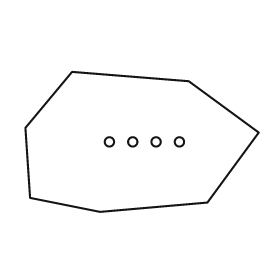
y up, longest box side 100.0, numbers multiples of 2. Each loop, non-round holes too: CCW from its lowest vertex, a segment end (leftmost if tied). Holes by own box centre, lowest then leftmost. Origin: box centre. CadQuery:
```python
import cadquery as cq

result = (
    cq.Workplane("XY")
    .moveTo(-18.0, -30.0)
    .lineTo(28.0, -26.0)
    .lineTo(50.0, 4.0)
    .lineTo(20.0, 26.0)
    .lineTo(-30.0, 30.0)
    .lineTo(-50.0, 6.0)
    .lineTo(-48.0, -24.0)
    .close()
    .moveTo(-14.0, 0.0)
    .circle(2.0)
    .moveTo(-4.0, 0.0)
    .circle(2.0)
    .moveTo(6.0, 0.0)
    .circle(2.0)
    .moveTo(16.0, 0.0)
    .circle(2.0)
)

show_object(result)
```